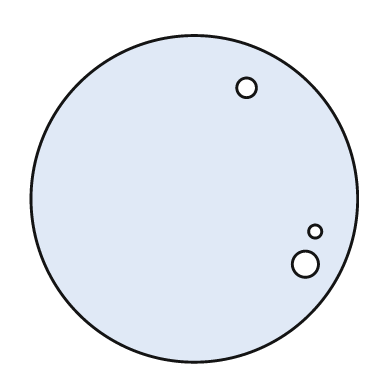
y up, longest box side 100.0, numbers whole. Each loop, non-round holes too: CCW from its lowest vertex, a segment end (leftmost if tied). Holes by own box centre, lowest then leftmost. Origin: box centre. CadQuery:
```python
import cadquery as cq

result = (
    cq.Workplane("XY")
    .moveTo(0.0, 0.0)
    .circle(50.0)
    .moveTo(34.0, -20.0)
    .circle(4.0)
    .moveTo(37.0, -10.0)
    .circle(2.0)
    .moveTo(16.0, 34.0)
    .circle(3.0)
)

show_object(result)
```